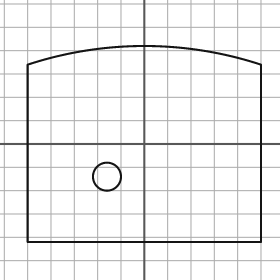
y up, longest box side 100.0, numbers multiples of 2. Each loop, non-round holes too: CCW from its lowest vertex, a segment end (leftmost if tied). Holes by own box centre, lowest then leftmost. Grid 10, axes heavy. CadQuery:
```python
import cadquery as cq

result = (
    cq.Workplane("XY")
    .moveTo(-50.0, -42.0)
    .lineTo(50.0, -42.0)
    .lineTo(50.0, 34.0)
    .threePointArc((0.0, 42.0), (-50.0, 34.0))
    .close()
    .moveTo(-16.0, -14.0)
    .circle(6.0)
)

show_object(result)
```